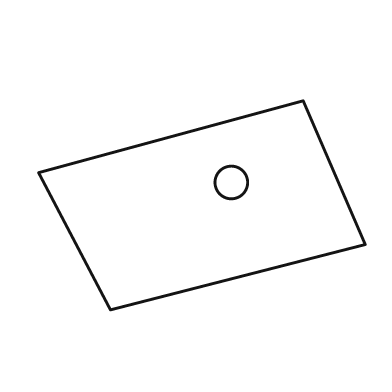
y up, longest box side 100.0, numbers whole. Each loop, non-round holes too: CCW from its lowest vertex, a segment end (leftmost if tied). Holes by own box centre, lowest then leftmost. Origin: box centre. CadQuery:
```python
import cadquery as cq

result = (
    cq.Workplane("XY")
    .moveTo(-28.0, -32.0)
    .lineTo(50.0, -12.0)
    .lineTo(31.0, 32.0)
    .lineTo(-50.0, 10.0)
    .close()
    .moveTo(9.0, 7.0)
    .circle(5.0)
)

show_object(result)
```